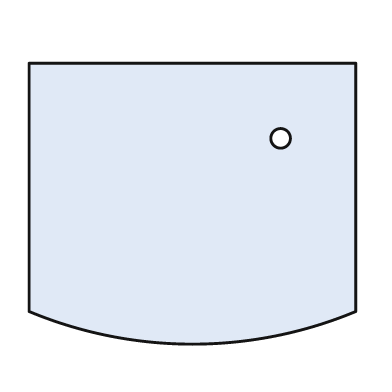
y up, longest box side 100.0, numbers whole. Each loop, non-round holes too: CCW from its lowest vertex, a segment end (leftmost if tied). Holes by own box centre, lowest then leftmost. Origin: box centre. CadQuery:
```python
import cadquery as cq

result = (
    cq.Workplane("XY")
    .moveTo(-50.0, -33.0)
    .threePointArc((0.0, -43.0), (50.0, -33.0))
    .lineTo(50.0, 43.0)
    .lineTo(-50.0, 43.0)
    .close()
    .moveTo(27.0, 20.0)
    .circle(3.0)
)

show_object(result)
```